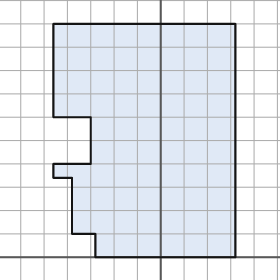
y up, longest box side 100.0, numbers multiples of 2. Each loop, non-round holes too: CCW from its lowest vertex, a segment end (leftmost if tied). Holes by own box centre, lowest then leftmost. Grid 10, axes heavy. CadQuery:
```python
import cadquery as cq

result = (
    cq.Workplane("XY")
    .moveTo(-28.0, 0.0)
    .lineTo(32.0, 0.0)
    .lineTo(32.0, 100.0)
    .lineTo(-46.0, 100.0)
    .lineTo(-46.0, 60.0)
    .lineTo(-30.0, 60.0)
    .lineTo(-30.0, 40.0)
    .lineTo(-46.0, 40.0)
    .lineTo(-46.0, 34.0)
    .lineTo(-38.0, 34.0)
    .lineTo(-38.0, 10.0)
    .lineTo(-28.0, 10.0)
    .close()
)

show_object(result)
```